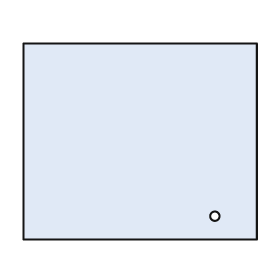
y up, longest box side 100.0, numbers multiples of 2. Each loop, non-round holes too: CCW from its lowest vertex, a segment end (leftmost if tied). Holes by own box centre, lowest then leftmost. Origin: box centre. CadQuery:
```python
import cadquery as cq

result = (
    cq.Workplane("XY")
    .moveTo(-50.0, -42.0)
    .lineTo(50.0, -42.0)
    .lineTo(50.0, 42.0)
    .lineTo(-50.0, 42.0)
    .close()
    .moveTo(32.0, -32.0)
    .circle(2.0)
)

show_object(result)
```